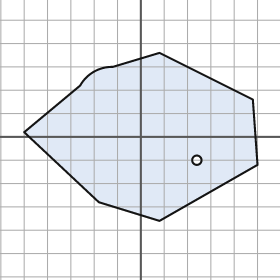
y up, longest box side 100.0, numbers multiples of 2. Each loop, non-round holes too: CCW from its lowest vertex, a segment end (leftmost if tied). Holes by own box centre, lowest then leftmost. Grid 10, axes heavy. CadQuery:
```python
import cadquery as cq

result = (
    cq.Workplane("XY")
    .moveTo(8.0, -36.0)
    .lineTo(50.0, -12.0)
    .lineTo(48.0, 16.0)
    .lineTo(8.0, 36.0)
    .lineTo(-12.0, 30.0)
    .threePointArc((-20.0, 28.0), (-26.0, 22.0))
    .lineTo(-50.0, 2.0)
    .lineTo(-18.0, -28.0)
    .close()
    .moveTo(24.0, -10.0)
    .circle(2.0)
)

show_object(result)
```